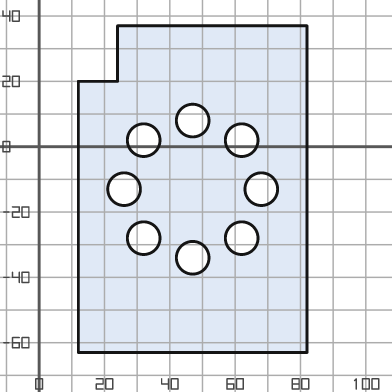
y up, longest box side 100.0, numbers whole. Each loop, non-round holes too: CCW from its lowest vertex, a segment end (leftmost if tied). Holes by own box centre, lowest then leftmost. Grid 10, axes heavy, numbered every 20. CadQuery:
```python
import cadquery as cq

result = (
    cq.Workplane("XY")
    .moveTo(12.0, -63.0)
    .lineTo(82.0, -63.0)
    .lineTo(82.0, 37.0)
    .lineTo(24.0, 37.0)
    .lineTo(24.0, 20.0)
    .lineTo(12.0, 20.0)
    .close()
    .moveTo(47.0, -34.0)
    .circle(5.0)
    .moveTo(32.0, -28.0)
    .circle(5.0)
    .moveTo(62.0, -28.0)
    .circle(5.0)
    .moveTo(26.0, -13.0)
    .circle(5.0)
    .moveTo(68.0, -13.0)
    .circle(5.0)
    .moveTo(32.0, 2.0)
    .circle(5.0)
    .moveTo(62.0, 2.0)
    .circle(5.0)
    .moveTo(47.0, 8.0)
    .circle(5.0)
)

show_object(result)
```